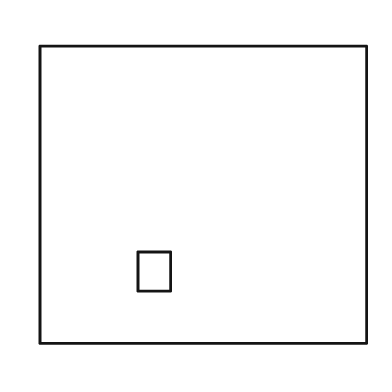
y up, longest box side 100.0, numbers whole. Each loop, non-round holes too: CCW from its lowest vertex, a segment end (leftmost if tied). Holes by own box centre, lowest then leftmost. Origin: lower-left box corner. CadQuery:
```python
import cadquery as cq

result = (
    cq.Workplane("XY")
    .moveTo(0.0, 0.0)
    .lineTo(100.0, 0.0)
    .lineTo(100.0, 91.0)
    .lineTo(0.0, 91.0)
    .close()
    .moveTo(30.0, 16.0)
    .lineTo(40.0, 16.0)
    .lineTo(40.0, 28.0)
    .lineTo(30.0, 28.0)
    .close()
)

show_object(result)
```